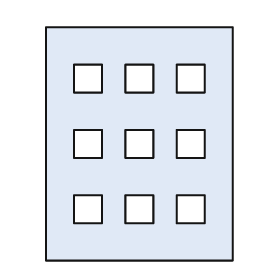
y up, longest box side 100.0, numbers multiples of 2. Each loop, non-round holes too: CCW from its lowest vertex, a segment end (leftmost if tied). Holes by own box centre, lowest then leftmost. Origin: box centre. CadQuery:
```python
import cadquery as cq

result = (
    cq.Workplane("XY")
    .moveTo(-40.0, -50.0)
    .lineTo(40.0, -50.0)
    .lineTo(40.0, 50.0)
    .lineTo(-40.0, 50.0)
    .close()
    .moveTo(-28.0, -34.0)
    .lineTo(-16.0, -34.0)
    .lineTo(-16.0, -22.0)
    .lineTo(-28.0, -22.0)
    .close()
    .moveTo(-6.0, -34.0)
    .lineTo(6.0, -34.0)
    .lineTo(6.0, -22.0)
    .lineTo(-6.0, -22.0)
    .close()
    .moveTo(16.0, -34.0)
    .lineTo(28.0, -34.0)
    .lineTo(28.0, -22.0)
    .lineTo(16.0, -22.0)
    .close()
    .moveTo(-28.0, -6.0)
    .lineTo(-16.0, -6.0)
    .lineTo(-16.0, 6.0)
    .lineTo(-28.0, 6.0)
    .close()
    .moveTo(-6.0, -6.0)
    .lineTo(6.0, -6.0)
    .lineTo(6.0, 6.0)
    .lineTo(-6.0, 6.0)
    .close()
    .moveTo(16.0, -6.0)
    .lineTo(28.0, -6.0)
    .lineTo(28.0, 6.0)
    .lineTo(16.0, 6.0)
    .close()
    .moveTo(-28.0, 22.0)
    .lineTo(-16.0, 22.0)
    .lineTo(-16.0, 34.0)
    .lineTo(-28.0, 34.0)
    .close()
    .moveTo(-6.0, 22.0)
    .lineTo(6.0, 22.0)
    .lineTo(6.0, 34.0)
    .lineTo(-6.0, 34.0)
    .close()
    .moveTo(16.0, 22.0)
    .lineTo(28.0, 22.0)
    .lineTo(28.0, 34.0)
    .lineTo(16.0, 34.0)
    .close()
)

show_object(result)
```